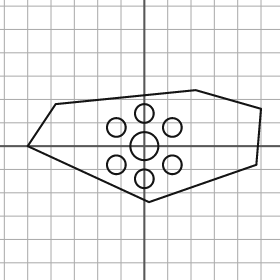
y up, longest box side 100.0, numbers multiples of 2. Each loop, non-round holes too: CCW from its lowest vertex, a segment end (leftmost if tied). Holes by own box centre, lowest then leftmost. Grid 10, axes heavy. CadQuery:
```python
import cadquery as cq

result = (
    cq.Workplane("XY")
    .moveTo(2.0, -24.0)
    .lineTo(48.0, -8.0)
    .lineTo(50.0, 16.0)
    .lineTo(22.0, 24.0)
    .lineTo(-38.0, 18.0)
    .lineTo(-50.0, 0.0)
    .close()
    .moveTo(0.0, -14.0)
    .circle(4.0)
    .moveTo(-12.0, -8.0)
    .circle(4.0)
    .moveTo(12.0, -8.0)
    .circle(4.0)
    .moveTo(0.0, 0.0)
    .circle(6.0)
    .moveTo(-12.0, 8.0)
    .circle(4.0)
    .moveTo(12.0, 8.0)
    .circle(4.0)
    .moveTo(0.0, 14.0)
    .circle(4.0)
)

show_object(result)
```